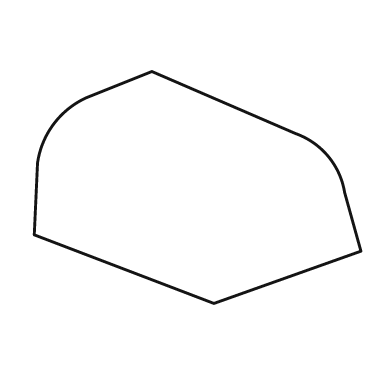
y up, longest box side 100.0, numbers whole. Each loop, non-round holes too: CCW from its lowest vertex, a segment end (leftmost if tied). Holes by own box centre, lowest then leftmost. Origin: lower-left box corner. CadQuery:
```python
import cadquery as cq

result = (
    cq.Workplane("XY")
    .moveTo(55.0, 0.0)
    .lineTo(100.0, 16.0)
    .lineTo(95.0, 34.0)
    .threePointArc((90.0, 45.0), (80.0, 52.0))
    .lineTo(36.0, 71.0)
    .lineTo(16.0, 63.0)
    .threePointArc((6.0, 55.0), (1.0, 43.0))
    .lineTo(0.0, 21.0)
    .close()
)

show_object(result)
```